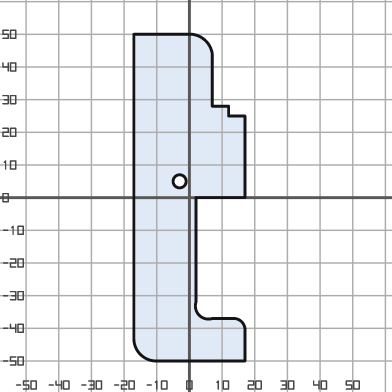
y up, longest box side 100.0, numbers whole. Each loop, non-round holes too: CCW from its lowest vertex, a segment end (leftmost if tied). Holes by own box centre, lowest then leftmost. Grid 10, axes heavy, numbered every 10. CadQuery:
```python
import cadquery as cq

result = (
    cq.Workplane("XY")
    .moveTo(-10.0, -50.0)
    .lineTo(17.0, -50.0)
    .lineTo(17.0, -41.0)
    .threePointArc((16.0, -38.0), (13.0, -37.0))
    .lineTo(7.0, -37.0)
    .threePointArc((3.0, -36.0), (2.0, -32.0))
    .lineTo(2.0, 0.0)
    .lineTo(17.0, 0.0)
    .lineTo(17.0, 25.0)
    .lineTo(12.0, 25.0)
    .lineTo(12.0, 28.0)
    .lineTo(7.0, 28.0)
    .lineTo(7.0, 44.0)
    .threePointArc((5.0, 48.0), (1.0, 50.0))
    .lineTo(-17.0, 50.0)
    .lineTo(-17.0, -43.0)
    .threePointArc((-15.0, -48.0), (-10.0, -50.0))
    .close()
    .moveTo(-3.0, 5.0)
    .circle(2.0)
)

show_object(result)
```